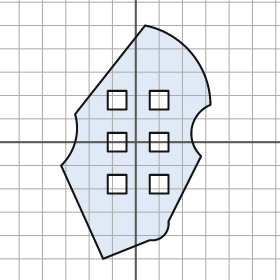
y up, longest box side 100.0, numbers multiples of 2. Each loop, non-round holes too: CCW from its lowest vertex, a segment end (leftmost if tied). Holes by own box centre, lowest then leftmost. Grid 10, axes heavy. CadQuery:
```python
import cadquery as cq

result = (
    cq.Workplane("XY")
    .moveTo(-14.0, -50.0)
    .lineTo(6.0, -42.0)
    .threePointArc((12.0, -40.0), (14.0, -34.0))
    .lineTo(28.0, -6.0)
    .threePointArc((24.0, 6.0), (32.0, 16.0))
    .threePointArc((24.0, 38.0), (4.0, 50.0))
    .lineTo(-26.0, 12.0)
    .threePointArc((-26.0, 0.0), (-32.0, -10.0))
    .close()
    .moveTo(-12.0, -22.0)
    .lineTo(-4.0, -22.0)
    .lineTo(-4.0, -14.0)
    .lineTo(-12.0, -14.0)
    .close()
    .moveTo(6.0, -22.0)
    .lineTo(14.0, -22.0)
    .lineTo(14.0, -14.0)
    .lineTo(6.0, -14.0)
    .close()
    .moveTo(-12.0, -4.0)
    .lineTo(-4.0, -4.0)
    .lineTo(-4.0, 4.0)
    .lineTo(-12.0, 4.0)
    .close()
    .moveTo(6.0, -4.0)
    .lineTo(14.0, -4.0)
    .lineTo(14.0, 4.0)
    .lineTo(6.0, 4.0)
    .close()
    .moveTo(-12.0, 14.0)
    .lineTo(-4.0, 14.0)
    .lineTo(-4.0, 22.0)
    .lineTo(-12.0, 22.0)
    .close()
    .moveTo(6.0, 14.0)
    .lineTo(14.0, 14.0)
    .lineTo(14.0, 22.0)
    .lineTo(6.0, 22.0)
    .close()
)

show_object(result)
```